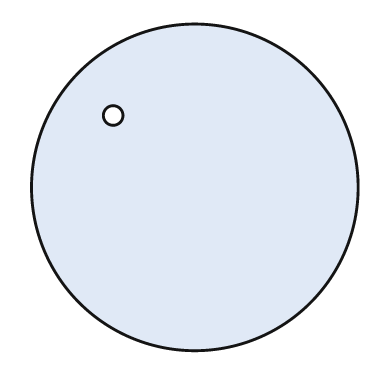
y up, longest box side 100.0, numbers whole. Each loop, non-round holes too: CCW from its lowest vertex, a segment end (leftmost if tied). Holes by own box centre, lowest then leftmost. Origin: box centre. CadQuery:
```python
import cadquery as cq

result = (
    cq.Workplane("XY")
    .moveTo(0.0, 0.0)
    .circle(50.0)
    .moveTo(-25.0, 22.0)
    .circle(3.0)
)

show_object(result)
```